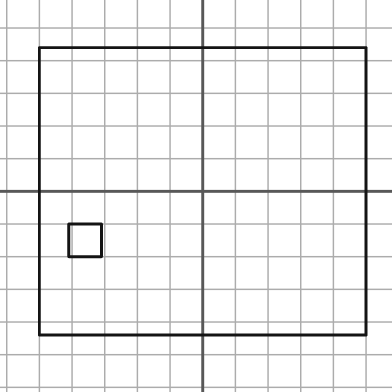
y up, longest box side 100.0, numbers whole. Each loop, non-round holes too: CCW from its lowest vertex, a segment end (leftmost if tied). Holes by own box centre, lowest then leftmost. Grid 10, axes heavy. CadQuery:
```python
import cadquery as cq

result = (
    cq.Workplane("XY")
    .moveTo(-50.0, -44.0)
    .lineTo(50.0, -44.0)
    .lineTo(50.0, 44.0)
    .lineTo(-50.0, 44.0)
    .close()
    .moveTo(-41.0, -20.0)
    .lineTo(-31.0, -20.0)
    .lineTo(-31.0, -10.0)
    .lineTo(-41.0, -10.0)
    .close()
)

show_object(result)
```